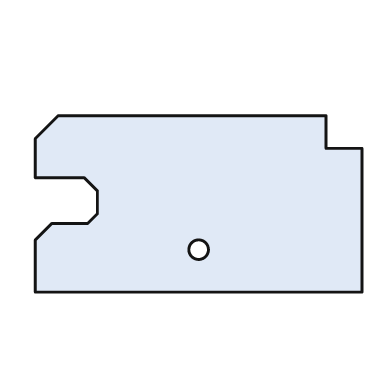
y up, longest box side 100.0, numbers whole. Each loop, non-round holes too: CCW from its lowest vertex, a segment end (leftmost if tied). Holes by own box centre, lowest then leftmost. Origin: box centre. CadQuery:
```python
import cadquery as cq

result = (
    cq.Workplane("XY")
    .moveTo(-50.0, -27.0)
    .lineTo(50.0, -27.0)
    .lineTo(50.0, 17.0)
    .lineTo(39.0, 17.0)
    .lineTo(39.0, 27.0)
    .lineTo(-43.0, 27.0)
    .lineTo(-50.0, 20.0)
    .lineTo(-50.0, 8.0)
    .lineTo(-35.0, 8.0)
    .lineTo(-31.0, 4.0)
    .lineTo(-31.0, -3.0)
    .lineTo(-34.0, -6.0)
    .lineTo(-45.0, -6.0)
    .lineTo(-50.0, -11.0)
    .close()
    .moveTo(0.0, -14.0)
    .circle(3.0)
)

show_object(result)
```